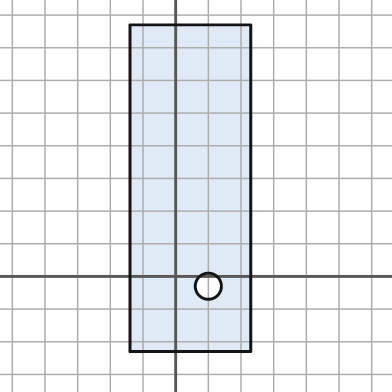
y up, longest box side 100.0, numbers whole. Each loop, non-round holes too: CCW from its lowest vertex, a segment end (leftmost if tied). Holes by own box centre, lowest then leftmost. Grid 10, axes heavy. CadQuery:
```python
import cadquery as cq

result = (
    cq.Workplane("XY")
    .moveTo(-14.0, -23.0)
    .lineTo(23.0, -23.0)
    .lineTo(23.0, 77.0)
    .lineTo(-14.0, 77.0)
    .close()
    .moveTo(10.0, -3.0)
    .circle(4.0)
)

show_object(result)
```